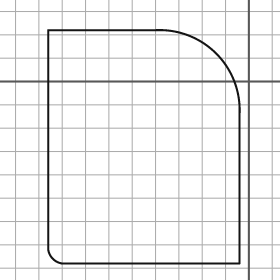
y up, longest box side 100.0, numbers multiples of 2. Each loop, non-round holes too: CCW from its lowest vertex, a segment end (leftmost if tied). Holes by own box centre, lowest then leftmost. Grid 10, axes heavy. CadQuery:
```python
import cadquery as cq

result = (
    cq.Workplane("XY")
    .moveTo(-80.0, -78.0)
    .lineTo(-4.0, -78.0)
    .lineTo(-4.0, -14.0)
    .threePointArc((-14.0, 12.0), (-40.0, 22.0))
    .lineTo(-86.0, 22.0)
    .lineTo(-86.0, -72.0)
    .threePointArc((-84.0, -76.0), (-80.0, -78.0))
    .close()
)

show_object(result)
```